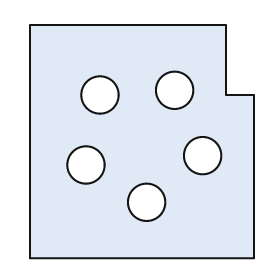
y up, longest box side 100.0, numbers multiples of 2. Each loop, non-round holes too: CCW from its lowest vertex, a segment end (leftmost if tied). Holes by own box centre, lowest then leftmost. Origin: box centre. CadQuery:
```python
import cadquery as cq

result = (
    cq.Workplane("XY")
    .moveTo(-48.0, -50.0)
    .lineTo(48.0, -50.0)
    .lineTo(48.0, 20.0)
    .lineTo(36.0, 20.0)
    .lineTo(36.0, 50.0)
    .lineTo(-48.0, 50.0)
    .close()
    .moveTo(2.0, -26.0)
    .circle(8.0)
    .moveTo(-24.0, -10.0)
    .circle(8.0)
    .moveTo(26.0, -6.0)
    .circle(8.0)
    .moveTo(-18.0, 20.0)
    .circle(8.0)
    .moveTo(14.0, 22.0)
    .circle(8.0)
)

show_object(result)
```